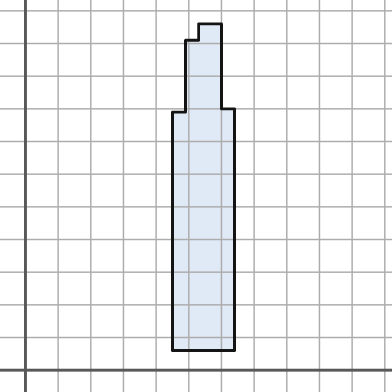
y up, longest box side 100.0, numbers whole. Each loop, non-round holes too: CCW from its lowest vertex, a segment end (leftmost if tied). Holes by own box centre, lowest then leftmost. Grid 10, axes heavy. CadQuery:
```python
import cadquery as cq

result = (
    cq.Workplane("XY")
    .moveTo(45.0, 6.0)
    .lineTo(64.0, 6.0)
    .lineTo(64.0, 80.0)
    .lineTo(60.0, 80.0)
    .lineTo(60.0, 106.0)
    .lineTo(53.0, 106.0)
    .lineTo(53.0, 101.0)
    .lineTo(49.0, 101.0)
    .lineTo(49.0, 79.0)
    .lineTo(45.0, 79.0)
    .close()
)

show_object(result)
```